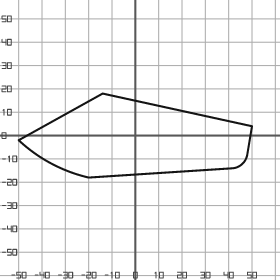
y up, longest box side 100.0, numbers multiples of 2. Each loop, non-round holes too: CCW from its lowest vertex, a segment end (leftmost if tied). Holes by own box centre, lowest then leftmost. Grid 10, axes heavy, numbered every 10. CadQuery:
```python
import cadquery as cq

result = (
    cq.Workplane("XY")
    .moveTo(-20.0, -18.0)
    .lineTo(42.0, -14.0)
    .threePointArc((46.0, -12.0), (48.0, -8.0))
    .lineTo(50.0, 4.0)
    .lineTo(-14.0, 18.0)
    .lineTo(-50.0, -2.0)
    .threePointArc((-36.0, -12.0), (-20.0, -18.0))
    .close()
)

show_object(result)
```